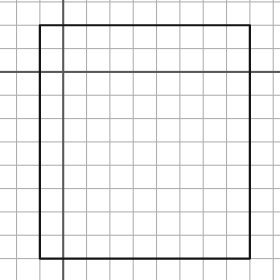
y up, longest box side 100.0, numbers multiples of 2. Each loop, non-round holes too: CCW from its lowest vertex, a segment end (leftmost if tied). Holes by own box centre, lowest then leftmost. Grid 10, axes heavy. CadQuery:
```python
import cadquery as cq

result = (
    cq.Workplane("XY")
    .moveTo(-10.0, -80.0)
    .lineTo(80.0, -80.0)
    .lineTo(80.0, 20.0)
    .lineTo(-10.0, 20.0)
    .close()
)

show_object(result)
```